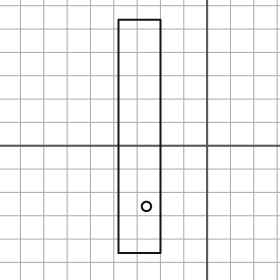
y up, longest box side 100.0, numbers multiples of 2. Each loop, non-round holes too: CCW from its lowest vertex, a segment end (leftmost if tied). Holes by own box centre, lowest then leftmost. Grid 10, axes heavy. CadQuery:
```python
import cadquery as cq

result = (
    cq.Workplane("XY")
    .moveTo(-38.0, -46.0)
    .lineTo(-20.0, -46.0)
    .lineTo(-20.0, 54.0)
    .lineTo(-38.0, 54.0)
    .close()
    .moveTo(-26.0, -26.0)
    .circle(2.0)
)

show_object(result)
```